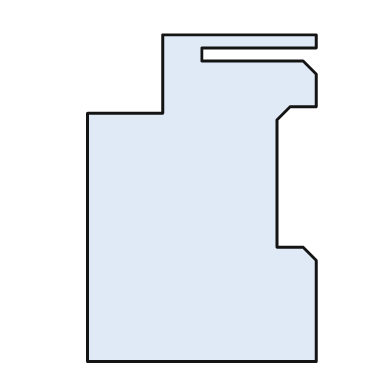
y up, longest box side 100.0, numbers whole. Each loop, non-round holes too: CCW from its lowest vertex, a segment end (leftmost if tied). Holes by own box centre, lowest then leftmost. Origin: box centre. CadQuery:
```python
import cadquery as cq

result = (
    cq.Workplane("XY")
    .moveTo(-35.0, -50.0)
    .lineTo(35.0, -50.0)
    .lineTo(35.0, -19.0)
    .lineTo(31.0, -15.0)
    .lineTo(23.0, -15.0)
    .lineTo(23.0, 24.0)
    .lineTo(27.0, 28.0)
    .lineTo(35.0, 28.0)
    .lineTo(35.0, 38.0)
    .lineTo(31.0, 42.0)
    .lineTo(0.0, 42.0)
    .lineTo(0.0, 46.0)
    .lineTo(35.0, 46.0)
    .lineTo(35.0, 50.0)
    .lineTo(-12.0, 50.0)
    .lineTo(-12.0, 26.0)
    .lineTo(-35.0, 26.0)
    .close()
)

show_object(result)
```